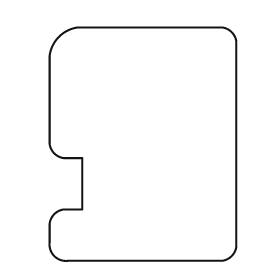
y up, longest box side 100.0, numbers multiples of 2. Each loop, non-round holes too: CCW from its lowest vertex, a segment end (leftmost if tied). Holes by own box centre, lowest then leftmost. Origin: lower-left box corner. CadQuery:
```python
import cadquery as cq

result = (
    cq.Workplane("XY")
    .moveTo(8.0, 0.0)
    .lineTo(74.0, 0.0)
    .threePointArc((78.0, 2.0), (80.0, 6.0))
    .lineTo(80.0, 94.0)
    .threePointArc((78.0, 98.0), (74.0, 100.0))
    .lineTo(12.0, 100.0)
    .threePointArc((4.0, 96.0), (0.0, 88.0))
    .lineTo(0.0, 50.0)
    .threePointArc((2.0, 46.0), (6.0, 44.0))
    .lineTo(14.0, 44.0)
    .lineTo(14.0, 22.0)
    .lineTo(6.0, 22.0)
    .threePointArc((2.0, 20.0), (0.0, 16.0))
    .lineTo(0.0, 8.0)
    .threePointArc((2.0, 2.0), (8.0, 0.0))
    .close()
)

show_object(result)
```